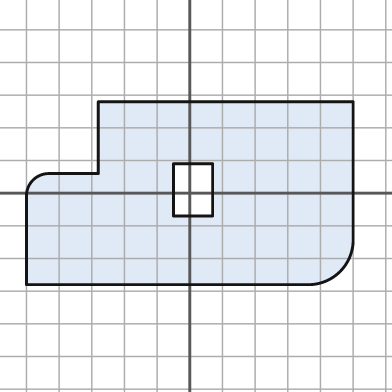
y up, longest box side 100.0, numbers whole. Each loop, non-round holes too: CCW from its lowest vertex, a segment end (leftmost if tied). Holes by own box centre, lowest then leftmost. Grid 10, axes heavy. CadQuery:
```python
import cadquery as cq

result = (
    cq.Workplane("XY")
    .moveTo(-50.0, -28.0)
    .lineTo(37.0, -28.0)
    .threePointArc((46.0, -24.0), (50.0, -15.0))
    .lineTo(50.0, 28.0)
    .lineTo(-28.0, 28.0)
    .lineTo(-28.0, 6.0)
    .lineTo(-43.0, 6.0)
    .threePointArc((-48.0, 4.0), (-50.0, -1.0))
    .close()
    .moveTo(-5.0, -7.0)
    .lineTo(7.0, -7.0)
    .lineTo(7.0, 9.0)
    .lineTo(-5.0, 9.0)
    .close()
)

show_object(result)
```